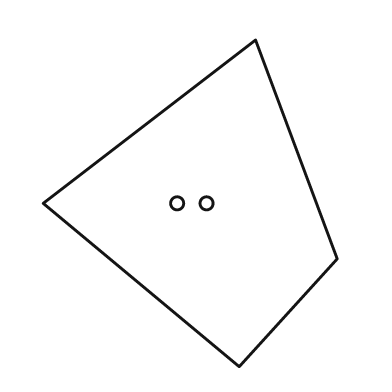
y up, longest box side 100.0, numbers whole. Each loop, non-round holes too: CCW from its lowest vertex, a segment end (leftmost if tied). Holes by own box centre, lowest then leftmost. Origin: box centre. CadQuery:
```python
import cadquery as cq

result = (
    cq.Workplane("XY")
    .moveTo(15.0, -50.0)
    .lineTo(45.0, -17.0)
    .lineTo(20.0, 50.0)
    .lineTo(-45.0, 0.0)
    .close()
    .moveTo(-4.0, 0.0)
    .circle(2.0)
    .moveTo(5.0, 0.0)
    .circle(2.0)
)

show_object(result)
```